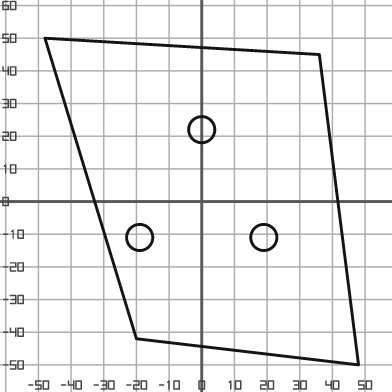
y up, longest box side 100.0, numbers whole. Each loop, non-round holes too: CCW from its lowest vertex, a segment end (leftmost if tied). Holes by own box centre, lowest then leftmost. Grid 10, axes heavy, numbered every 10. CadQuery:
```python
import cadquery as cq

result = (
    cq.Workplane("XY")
    .moveTo(48.0, -50.0)
    .lineTo(36.0, 45.0)
    .lineTo(-48.0, 50.0)
    .lineTo(-20.0, -42.0)
    .close()
    .moveTo(-19.0, -11.0)
    .circle(4.0)
    .moveTo(19.0, -11.0)
    .circle(4.0)
    .moveTo(0.0, 22.0)
    .circle(4.0)
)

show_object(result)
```